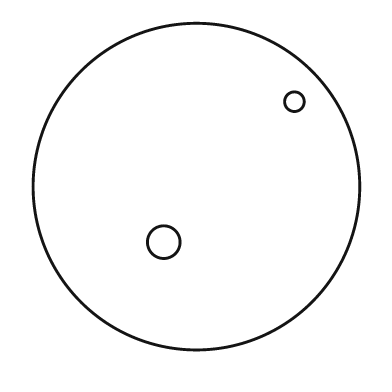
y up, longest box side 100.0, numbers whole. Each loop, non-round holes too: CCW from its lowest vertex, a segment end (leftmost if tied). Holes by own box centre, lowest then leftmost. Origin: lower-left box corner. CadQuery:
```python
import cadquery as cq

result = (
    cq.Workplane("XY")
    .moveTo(50.0, 50.0)
    .circle(50.0)
    .moveTo(40.0, 33.0)
    .circle(5.0)
    .moveTo(80.0, 76.0)
    .circle(3.0)
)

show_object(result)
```